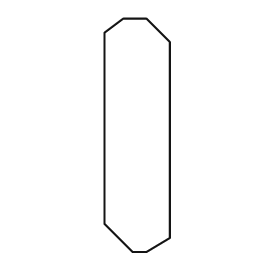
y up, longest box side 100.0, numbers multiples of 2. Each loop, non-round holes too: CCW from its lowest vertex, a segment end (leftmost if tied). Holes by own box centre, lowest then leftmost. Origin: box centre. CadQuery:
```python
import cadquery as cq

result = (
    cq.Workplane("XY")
    .moveTo(-2.0, -50.0)
    .lineTo(4.0, -50.0)
    .lineTo(14.0, -44.0)
    .lineTo(14.0, 40.0)
    .lineTo(4.0, 50.0)
    .lineTo(-6.0, 50.0)
    .lineTo(-14.0, 44.0)
    .lineTo(-14.0, -38.0)
    .close()
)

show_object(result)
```